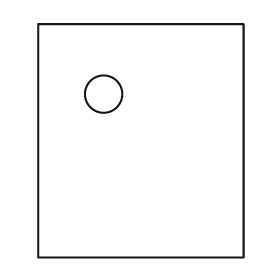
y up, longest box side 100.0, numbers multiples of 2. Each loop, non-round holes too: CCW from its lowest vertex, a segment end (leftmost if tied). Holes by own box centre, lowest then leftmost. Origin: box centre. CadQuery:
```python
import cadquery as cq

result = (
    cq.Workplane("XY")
    .moveTo(-44.0, -50.0)
    .lineTo(44.0, -50.0)
    .lineTo(44.0, 50.0)
    .lineTo(-44.0, 50.0)
    .close()
    .moveTo(-16.0, 20.0)
    .circle(8.0)
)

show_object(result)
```